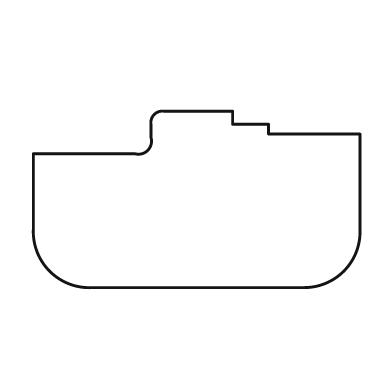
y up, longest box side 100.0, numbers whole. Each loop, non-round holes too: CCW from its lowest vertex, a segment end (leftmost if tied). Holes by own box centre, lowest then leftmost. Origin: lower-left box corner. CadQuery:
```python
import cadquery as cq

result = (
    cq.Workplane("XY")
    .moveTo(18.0, 0.0)
    .lineTo(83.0, 0.0)
    .threePointArc((95.0, 5.0), (100.0, 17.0))
    .lineTo(100.0, 47.0)
    .lineTo(72.0, 47.0)
    .lineTo(72.0, 50.0)
    .lineTo(61.0, 50.0)
    .lineTo(61.0, 54.0)
    .lineTo(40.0, 54.0)
    .threePointArc((37.0, 53.0), (36.0, 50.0))
    .lineTo(36.0, 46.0)
    .threePointArc((35.0, 42.0), (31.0, 41.0))
    .lineTo(0.0, 41.0)
    .lineTo(0.0, 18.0)
    .threePointArc((5.0, 5.0), (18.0, 0.0))
    .close()
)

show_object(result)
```